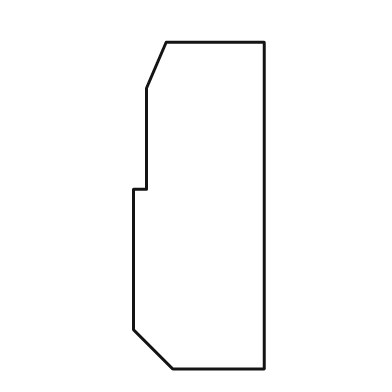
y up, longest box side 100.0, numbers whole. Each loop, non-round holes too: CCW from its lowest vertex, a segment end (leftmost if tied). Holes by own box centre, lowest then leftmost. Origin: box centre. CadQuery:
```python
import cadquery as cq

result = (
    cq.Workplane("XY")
    .moveTo(-8.0, -50.0)
    .lineTo(20.0, -50.0)
    .lineTo(20.0, 50.0)
    .lineTo(-10.0, 50.0)
    .lineTo(-16.0, 36.0)
    .lineTo(-16.0, 5.0)
    .lineTo(-20.0, 5.0)
    .lineTo(-20.0, -38.0)
    .close()
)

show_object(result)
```